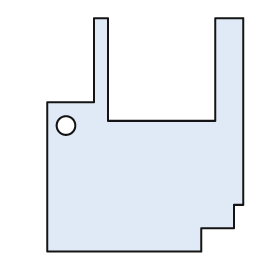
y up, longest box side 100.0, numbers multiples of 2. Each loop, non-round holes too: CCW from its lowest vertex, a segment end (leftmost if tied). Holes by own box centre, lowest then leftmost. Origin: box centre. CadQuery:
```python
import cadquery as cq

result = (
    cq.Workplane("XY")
    .moveTo(-42.0, -50.0)
    .lineTo(24.0, -50.0)
    .lineTo(24.0, -40.0)
    .lineTo(38.0, -40.0)
    .lineTo(38.0, -30.0)
    .lineTo(42.0, -30.0)
    .lineTo(42.0, 50.0)
    .lineTo(30.0, 50.0)
    .lineTo(30.0, 6.0)
    .lineTo(-16.0, 6.0)
    .lineTo(-16.0, 50.0)
    .lineTo(-22.0, 50.0)
    .lineTo(-22.0, 14.0)
    .lineTo(-42.0, 14.0)
    .close()
    .moveTo(-34.0, 4.0)
    .circle(4.0)
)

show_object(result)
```